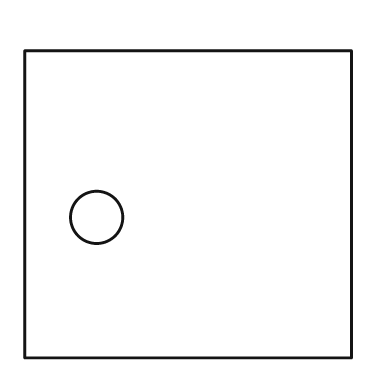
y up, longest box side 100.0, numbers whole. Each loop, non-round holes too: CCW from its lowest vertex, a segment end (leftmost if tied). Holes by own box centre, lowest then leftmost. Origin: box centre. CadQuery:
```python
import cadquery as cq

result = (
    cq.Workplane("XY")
    .moveTo(-50.0, -47.0)
    .lineTo(50.0, -47.0)
    .lineTo(50.0, 47.0)
    .lineTo(-50.0, 47.0)
    .close()
    .moveTo(-28.0, -4.0)
    .circle(8.0)
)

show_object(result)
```